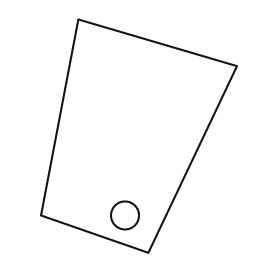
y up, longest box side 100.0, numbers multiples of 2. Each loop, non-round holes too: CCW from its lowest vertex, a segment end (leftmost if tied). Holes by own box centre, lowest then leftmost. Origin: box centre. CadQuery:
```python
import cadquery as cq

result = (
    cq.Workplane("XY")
    .moveTo(4.0, -50.0)
    .lineTo(42.0, 30.0)
    .lineTo(-26.0, 50.0)
    .lineTo(-42.0, -34.0)
    .close()
    .moveTo(-6.0, -34.0)
    .circle(6.0)
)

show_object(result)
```